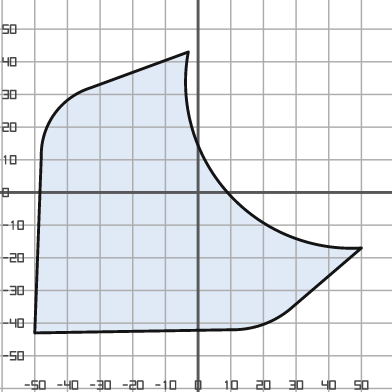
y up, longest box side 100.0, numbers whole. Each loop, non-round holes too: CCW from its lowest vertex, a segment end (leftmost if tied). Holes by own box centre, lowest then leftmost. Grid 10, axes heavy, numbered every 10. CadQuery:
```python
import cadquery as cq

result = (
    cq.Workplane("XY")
    .moveTo(-50.0, -43.0)
    .lineTo(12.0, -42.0)
    .threePointArc((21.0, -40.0), (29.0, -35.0))
    .lineTo(50.0, -17.0)
    .threePointArc((9.0, 0.0), (-3.0, 43.0))
    .lineTo(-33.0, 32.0)
    .threePointArc((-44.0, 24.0), (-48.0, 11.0))
    .close()
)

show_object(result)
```